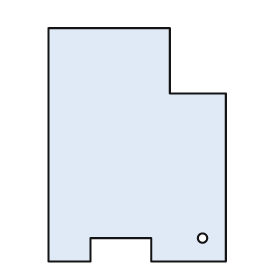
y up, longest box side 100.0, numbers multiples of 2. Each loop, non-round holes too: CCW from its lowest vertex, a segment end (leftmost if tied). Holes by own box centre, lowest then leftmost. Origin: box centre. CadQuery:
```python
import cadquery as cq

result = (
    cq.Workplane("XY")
    .moveTo(-38.0, -50.0)
    .lineTo(-20.0, -50.0)
    .lineTo(-20.0, -40.0)
    .lineTo(6.0, -40.0)
    .lineTo(6.0, -50.0)
    .lineTo(38.0, -50.0)
    .lineTo(38.0, 22.0)
    .lineTo(14.0, 22.0)
    .lineTo(14.0, 50.0)
    .lineTo(-38.0, 50.0)
    .close()
    .moveTo(28.0, -40.0)
    .circle(2.0)
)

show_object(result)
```